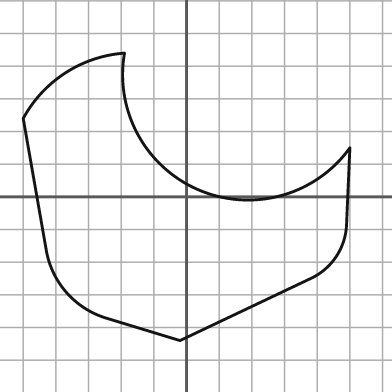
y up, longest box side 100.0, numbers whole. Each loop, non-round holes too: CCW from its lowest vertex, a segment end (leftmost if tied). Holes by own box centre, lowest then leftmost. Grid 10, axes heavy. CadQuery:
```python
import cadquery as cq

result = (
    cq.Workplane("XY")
    .moveTo(-2.0, -44.0)
    .lineTo(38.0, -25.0)
    .threePointArc((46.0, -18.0), (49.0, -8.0))
    .lineTo(50.0, 15.0)
    .threePointArc((4.0, 2.0), (-19.0, 44.0))
    .threePointArc((-37.0, 38.0), (-50.0, 24.0))
    .lineTo(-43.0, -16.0)
    .threePointArc((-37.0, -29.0), (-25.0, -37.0))
    .close()
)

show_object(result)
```